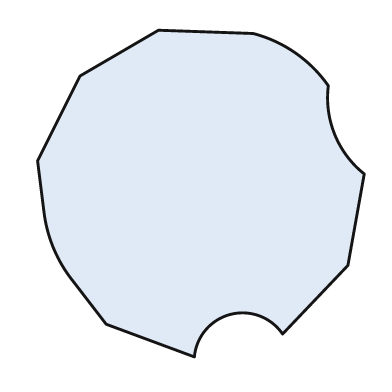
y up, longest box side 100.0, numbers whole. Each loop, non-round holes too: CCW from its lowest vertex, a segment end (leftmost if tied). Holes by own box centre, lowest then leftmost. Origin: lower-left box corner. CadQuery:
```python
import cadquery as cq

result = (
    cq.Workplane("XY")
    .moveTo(48.0, 0.0)
    .threePointArc((59.0, 13.0), (75.0, 7.0))
    .lineTo(95.0, 28.0)
    .lineTo(100.0, 56.0)
    .threePointArc((91.0, 68.0), (89.0, 83.0))
    .threePointArc((79.0, 93.0), (66.0, 99.0))
    .lineTo(37.0, 100.0)
    .lineTo(13.0, 86.0)
    .lineTo(0.0, 60.0)
    .lineTo(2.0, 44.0)
    .threePointArc((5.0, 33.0), (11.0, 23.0))
    .lineTo(21.0, 10.0)
    .close()
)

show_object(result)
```